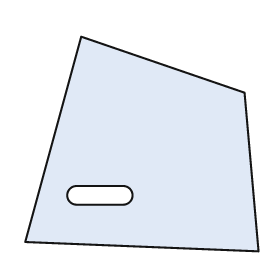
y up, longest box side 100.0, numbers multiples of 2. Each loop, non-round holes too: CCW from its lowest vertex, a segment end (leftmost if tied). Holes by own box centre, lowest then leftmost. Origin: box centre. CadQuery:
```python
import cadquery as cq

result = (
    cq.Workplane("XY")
    .moveTo(50.0, -46.0)
    .lineTo(44.0, 22.0)
    .lineTo(-26.0, 46.0)
    .lineTo(-50.0, -42.0)
    .close()
    .moveTo(-28.0, -26.0)
    .lineTo(-8.0, -26.0)
    .threePointArc((-4.0, -22.0), (-8.0, -18.0))
    .lineTo(-28.0, -18.0)
    .threePointArc((-32.0, -22.0), (-28.0, -26.0))
    .close()
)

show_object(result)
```